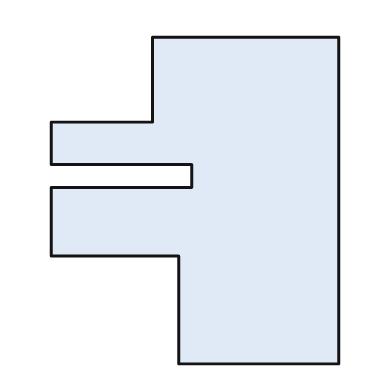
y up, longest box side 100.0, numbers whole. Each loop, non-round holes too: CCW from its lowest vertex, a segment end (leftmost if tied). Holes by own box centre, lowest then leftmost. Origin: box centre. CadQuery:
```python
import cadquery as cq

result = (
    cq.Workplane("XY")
    .moveTo(-5.0, -50.0)
    .lineTo(44.0, -50.0)
    .lineTo(44.0, 50.0)
    .lineTo(-13.0, 50.0)
    .lineTo(-13.0, 24.0)
    .lineTo(-44.0, 24.0)
    .lineTo(-44.0, 11.0)
    .lineTo(-1.0, 11.0)
    .lineTo(-1.0, 4.0)
    .lineTo(-44.0, 4.0)
    .lineTo(-44.0, -17.0)
    .lineTo(-5.0, -17.0)
    .close()
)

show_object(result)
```